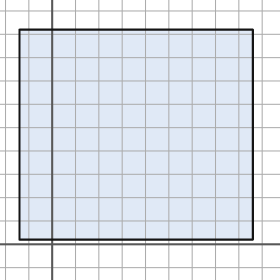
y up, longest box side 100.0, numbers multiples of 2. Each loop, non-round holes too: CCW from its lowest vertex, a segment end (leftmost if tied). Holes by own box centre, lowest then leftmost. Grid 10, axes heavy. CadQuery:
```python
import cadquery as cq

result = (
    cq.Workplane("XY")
    .moveTo(-14.0, 2.0)
    .lineTo(86.0, 2.0)
    .lineTo(86.0, 92.0)
    .lineTo(-14.0, 92.0)
    .close()
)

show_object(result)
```